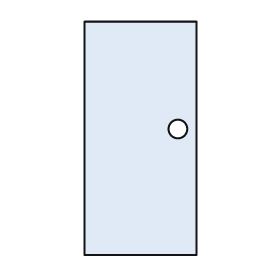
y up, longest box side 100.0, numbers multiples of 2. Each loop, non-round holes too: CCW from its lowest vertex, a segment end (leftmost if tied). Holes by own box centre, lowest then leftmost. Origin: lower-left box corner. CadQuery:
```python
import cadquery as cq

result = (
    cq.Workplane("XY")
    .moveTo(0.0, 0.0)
    .lineTo(48.0, 0.0)
    .lineTo(48.0, 100.0)
    .lineTo(0.0, 100.0)
    .close()
    .moveTo(40.0, 54.0)
    .circle(4.0)
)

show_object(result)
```